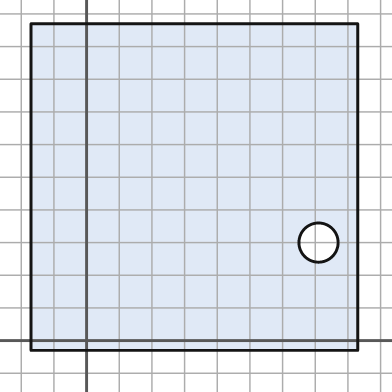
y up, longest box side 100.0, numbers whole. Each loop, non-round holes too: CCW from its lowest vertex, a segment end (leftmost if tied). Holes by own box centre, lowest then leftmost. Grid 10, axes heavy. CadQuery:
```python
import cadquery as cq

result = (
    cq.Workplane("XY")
    .moveTo(-17.0, -3.0)
    .lineTo(83.0, -3.0)
    .lineTo(83.0, 97.0)
    .lineTo(-17.0, 97.0)
    .close()
    .moveTo(71.0, 30.0)
    .circle(6.0)
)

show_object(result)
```